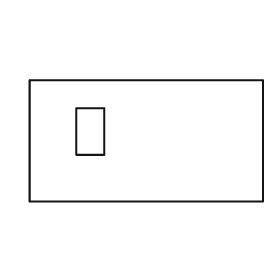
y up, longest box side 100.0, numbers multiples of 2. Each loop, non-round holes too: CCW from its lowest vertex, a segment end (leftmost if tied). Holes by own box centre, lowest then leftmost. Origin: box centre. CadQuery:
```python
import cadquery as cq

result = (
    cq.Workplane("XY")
    .moveTo(-50.0, -26.0)
    .lineTo(50.0, -26.0)
    .lineTo(50.0, 26.0)
    .lineTo(-50.0, 26.0)
    .close()
    .moveTo(-30.0, -6.0)
    .lineTo(-18.0, -6.0)
    .lineTo(-18.0, 14.0)
    .lineTo(-30.0, 14.0)
    .close()
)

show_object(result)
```